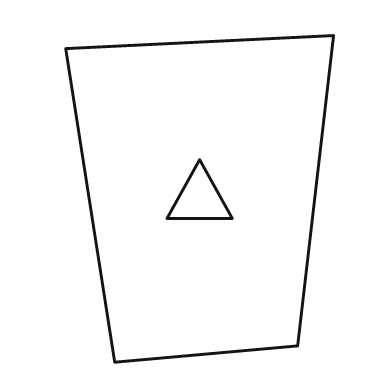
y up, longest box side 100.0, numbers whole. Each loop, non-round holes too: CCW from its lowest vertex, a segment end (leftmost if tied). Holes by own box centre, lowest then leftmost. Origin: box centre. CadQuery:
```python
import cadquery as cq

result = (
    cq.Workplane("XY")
    .moveTo(-26.0, -50.0)
    .lineTo(30.0, -45.0)
    .lineTo(41.0, 50.0)
    .lineTo(-41.0, 46.0)
    .close()
    .moveTo(-10.0, -6.0)
    .lineTo(10.0, -6.0)
    .lineTo(0.0, 12.0)
    .close()
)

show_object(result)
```